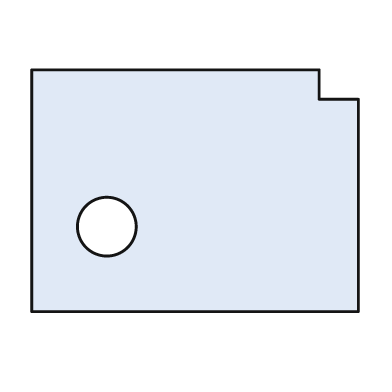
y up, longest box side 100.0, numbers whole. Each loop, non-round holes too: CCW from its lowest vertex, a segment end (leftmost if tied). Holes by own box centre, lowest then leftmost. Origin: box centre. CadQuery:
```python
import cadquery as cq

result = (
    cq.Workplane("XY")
    .moveTo(-50.0, -37.0)
    .lineTo(50.0, -37.0)
    .lineTo(50.0, 28.0)
    .lineTo(38.0, 28.0)
    .lineTo(38.0, 37.0)
    .lineTo(-50.0, 37.0)
    .close()
    .moveTo(-27.0, -11.0)
    .circle(9.0)
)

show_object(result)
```